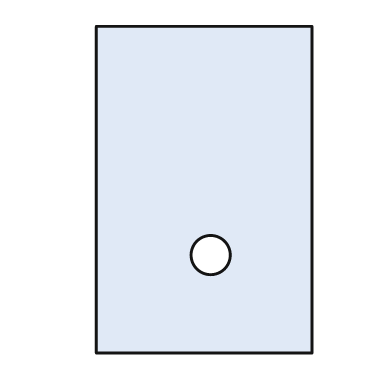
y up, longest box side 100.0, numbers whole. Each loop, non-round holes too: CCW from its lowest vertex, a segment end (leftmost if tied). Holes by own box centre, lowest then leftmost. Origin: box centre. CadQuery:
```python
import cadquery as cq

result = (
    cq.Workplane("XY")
    .moveTo(-33.0, -50.0)
    .lineTo(33.0, -50.0)
    .lineTo(33.0, 50.0)
    .lineTo(-33.0, 50.0)
    .close()
    .moveTo(2.0, -20.0)
    .circle(6.0)
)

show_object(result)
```